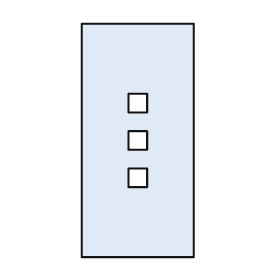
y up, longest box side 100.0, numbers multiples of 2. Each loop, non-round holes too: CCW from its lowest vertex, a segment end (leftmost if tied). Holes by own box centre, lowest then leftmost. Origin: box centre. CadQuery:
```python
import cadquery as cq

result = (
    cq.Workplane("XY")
    .moveTo(-24.0, -50.0)
    .lineTo(24.0, -50.0)
    .lineTo(24.0, 50.0)
    .lineTo(-24.0, 50.0)
    .close()
    .moveTo(-4.0, -20.0)
    .lineTo(4.0, -20.0)
    .lineTo(4.0, -12.0)
    .lineTo(-4.0, -12.0)
    .close()
    .moveTo(-4.0, -4.0)
    .lineTo(4.0, -4.0)
    .lineTo(4.0, 4.0)
    .lineTo(-4.0, 4.0)
    .close()
    .moveTo(-4.0, 12.0)
    .lineTo(4.0, 12.0)
    .lineTo(4.0, 20.0)
    .lineTo(-4.0, 20.0)
    .close()
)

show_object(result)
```